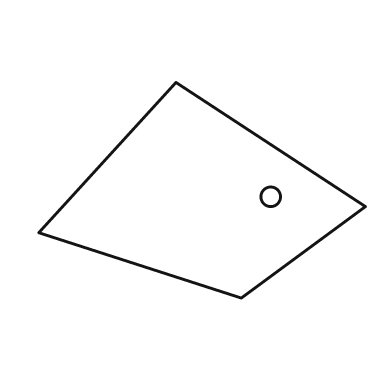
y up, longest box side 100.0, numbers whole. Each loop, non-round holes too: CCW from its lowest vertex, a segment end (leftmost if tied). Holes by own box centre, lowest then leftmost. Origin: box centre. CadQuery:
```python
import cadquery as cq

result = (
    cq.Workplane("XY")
    .moveTo(12.0, -33.0)
    .lineTo(50.0, -5.0)
    .lineTo(-8.0, 33.0)
    .lineTo(-50.0, -13.0)
    .close()
    .moveTo(21.0, -2.0)
    .circle(3.0)
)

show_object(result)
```